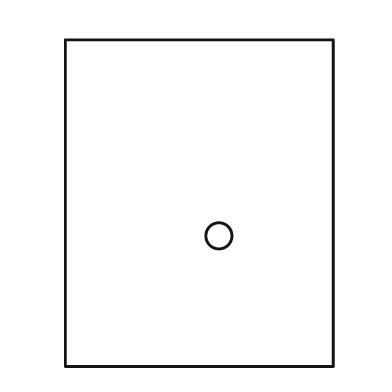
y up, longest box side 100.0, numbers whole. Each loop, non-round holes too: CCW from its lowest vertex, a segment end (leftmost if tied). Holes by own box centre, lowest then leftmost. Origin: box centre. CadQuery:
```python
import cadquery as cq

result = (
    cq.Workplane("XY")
    .moveTo(-41.0, -50.0)
    .lineTo(41.0, -50.0)
    .lineTo(41.0, 50.0)
    .lineTo(-41.0, 50.0)
    .close()
    .moveTo(6.0, -10.0)
    .circle(4.0)
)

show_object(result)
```